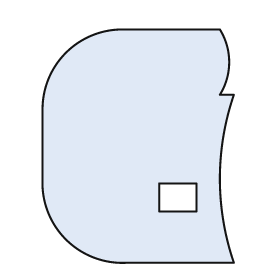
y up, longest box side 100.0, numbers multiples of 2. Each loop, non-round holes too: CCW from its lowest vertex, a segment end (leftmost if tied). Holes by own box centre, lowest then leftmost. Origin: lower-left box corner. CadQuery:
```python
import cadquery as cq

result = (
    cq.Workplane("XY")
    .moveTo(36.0, 0.0)
    .lineTo(82.0, 0.0)
    .threePointArc((76.0, 36.0), (82.0, 72.0))
    .lineTo(76.0, 72.0)
    .threePointArc((80.0, 86.0), (76.0, 100.0))
    .lineTo(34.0, 100.0)
    .threePointArc((10.0, 90.0), (0.0, 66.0))
    .lineTo(0.0, 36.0)
    .threePointArc((10.0, 10.0), (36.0, 0.0))
    .close()
    .moveTo(50.0, 22.0)
    .lineTo(66.0, 22.0)
    .lineTo(66.0, 34.0)
    .lineTo(50.0, 34.0)
    .close()
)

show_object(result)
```